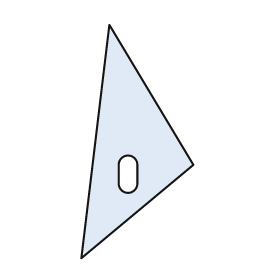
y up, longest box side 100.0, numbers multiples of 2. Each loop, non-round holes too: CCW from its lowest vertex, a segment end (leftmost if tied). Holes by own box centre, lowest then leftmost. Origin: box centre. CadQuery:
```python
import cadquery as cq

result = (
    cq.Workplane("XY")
    .moveTo(-24.0, -50.0)
    .lineTo(24.0, -10.0)
    .lineTo(-12.0, 50.0)
    .close()
    .moveTo(-8.0, -18.0)
    .threePointArc((-4.0, -22.0), (0.0, -18.0))
    .lineTo(0.0, -10.0)
    .threePointArc((-4.0, -6.0), (-8.0, -10.0))
    .close()
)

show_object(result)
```